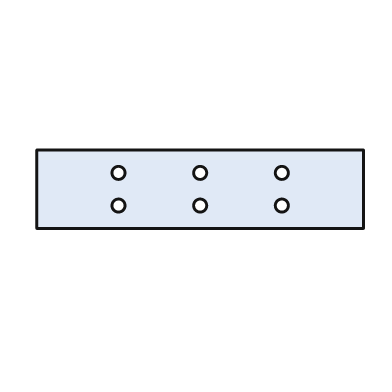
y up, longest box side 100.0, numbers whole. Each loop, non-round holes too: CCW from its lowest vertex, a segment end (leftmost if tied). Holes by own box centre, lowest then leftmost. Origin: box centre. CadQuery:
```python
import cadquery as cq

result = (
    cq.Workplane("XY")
    .moveTo(-50.0, -12.0)
    .lineTo(50.0, -12.0)
    .lineTo(50.0, 12.0)
    .lineTo(-50.0, 12.0)
    .close()
    .moveTo(-25.0, -5.0)
    .circle(2.0)
    .moveTo(0.0, -5.0)
    .circle(2.0)
    .moveTo(25.0, -5.0)
    .circle(2.0)
    .moveTo(-25.0, 5.0)
    .circle(2.0)
    .moveTo(0.0, 5.0)
    .circle(2.0)
    .moveTo(25.0, 5.0)
    .circle(2.0)
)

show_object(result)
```